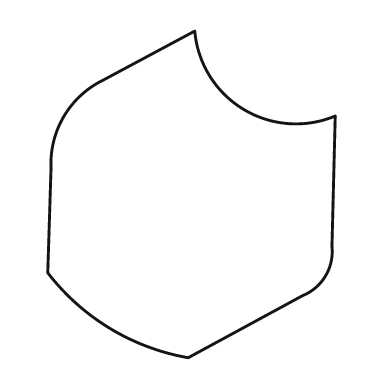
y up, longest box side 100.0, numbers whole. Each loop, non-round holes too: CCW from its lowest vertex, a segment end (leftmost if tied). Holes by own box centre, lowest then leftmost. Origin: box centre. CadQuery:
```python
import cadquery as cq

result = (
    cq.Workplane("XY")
    .moveTo(-1.0, -50.0)
    .lineTo(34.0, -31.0)
    .threePointArc((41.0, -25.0), (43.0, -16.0))
    .lineTo(44.0, 24.0)
    .threePointArc((16.0, 26.0), (1.0, 50.0))
    .lineTo(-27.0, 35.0)
    .threePointArc((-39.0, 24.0), (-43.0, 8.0))
    .lineTo(-44.0, -24.0)
    .threePointArc((-25.0, -41.0), (-1.0, -50.0))
    .close()
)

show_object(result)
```